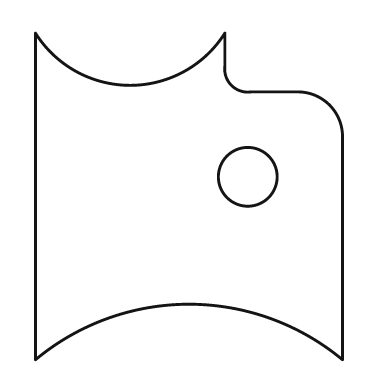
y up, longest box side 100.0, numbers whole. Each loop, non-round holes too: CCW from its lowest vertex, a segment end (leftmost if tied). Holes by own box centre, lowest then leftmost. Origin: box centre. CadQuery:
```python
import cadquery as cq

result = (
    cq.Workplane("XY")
    .moveTo(-47.0, -50.0)
    .threePointArc((0.0, -33.0), (47.0, -50.0))
    .lineTo(47.0, 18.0)
    .threePointArc((43.0, 28.0), (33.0, 32.0))
    .lineTo(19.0, 32.0)
    .threePointArc((13.0, 34.0), (11.0, 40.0))
    .lineTo(11.0, 50.0)
    .threePointArc((-18.0, 34.0), (-47.0, 50.0))
    .close()
    .moveTo(18.0, 6.0)
    .circle(9.0)
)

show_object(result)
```